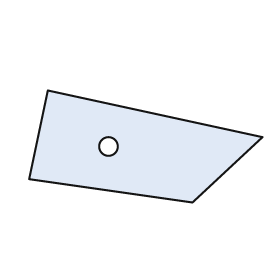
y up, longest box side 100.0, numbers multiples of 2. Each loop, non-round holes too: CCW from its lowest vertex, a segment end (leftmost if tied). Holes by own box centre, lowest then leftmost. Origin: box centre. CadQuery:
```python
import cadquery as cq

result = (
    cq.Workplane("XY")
    .moveTo(20.0, -24.0)
    .lineTo(50.0, 4.0)
    .lineTo(-42.0, 24.0)
    .lineTo(-50.0, -14.0)
    .close()
    .moveTo(-16.0, 0.0)
    .circle(4.0)
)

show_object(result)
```